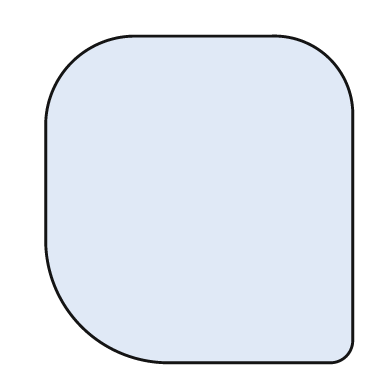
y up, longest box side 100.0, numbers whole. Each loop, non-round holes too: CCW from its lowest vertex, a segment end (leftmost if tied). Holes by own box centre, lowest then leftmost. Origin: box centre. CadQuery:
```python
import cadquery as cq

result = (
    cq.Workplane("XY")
    .moveTo(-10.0, -50.0)
    .lineTo(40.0, -50.0)
    .threePointArc((45.0, -48.0), (47.0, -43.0))
    .lineTo(47.0, 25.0)
    .threePointArc((40.0, 43.0), (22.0, 50.0))
    .lineTo(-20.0, 50.0)
    .threePointArc((-39.0, 42.0), (-47.0, 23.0))
    .lineTo(-47.0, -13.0)
    .threePointArc((-36.0, -39.0), (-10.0, -50.0))
    .close()
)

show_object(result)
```